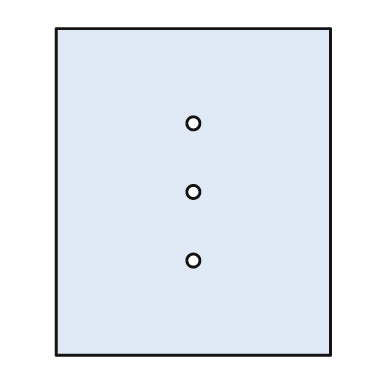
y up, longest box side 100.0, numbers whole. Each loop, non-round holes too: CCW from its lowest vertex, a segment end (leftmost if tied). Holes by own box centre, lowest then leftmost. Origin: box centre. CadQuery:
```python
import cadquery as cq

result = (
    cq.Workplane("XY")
    .moveTo(-42.0, -50.0)
    .lineTo(42.0, -50.0)
    .lineTo(42.0, 50.0)
    .lineTo(-42.0, 50.0)
    .close()
    .moveTo(0.0, -21.0)
    .circle(2.0)
    .moveTo(0.0, 0.0)
    .circle(2.0)
    .moveTo(0.0, 21.0)
    .circle(2.0)
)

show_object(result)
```